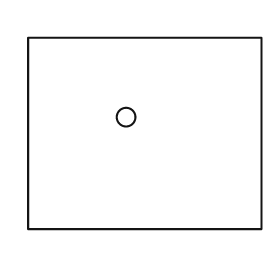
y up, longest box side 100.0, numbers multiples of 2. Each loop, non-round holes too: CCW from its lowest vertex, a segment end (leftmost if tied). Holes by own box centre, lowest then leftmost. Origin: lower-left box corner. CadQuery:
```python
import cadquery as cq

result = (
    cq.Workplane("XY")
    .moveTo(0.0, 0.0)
    .lineTo(100.0, 0.0)
    .lineTo(100.0, 82.0)
    .lineTo(0.0, 82.0)
    .close()
    .moveTo(42.0, 48.0)
    .circle(4.0)
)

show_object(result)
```